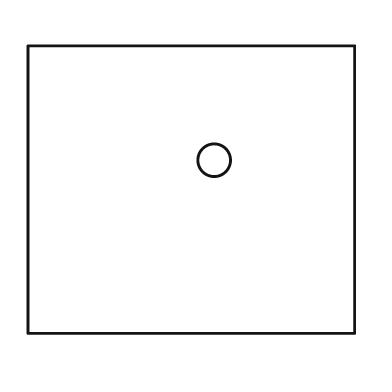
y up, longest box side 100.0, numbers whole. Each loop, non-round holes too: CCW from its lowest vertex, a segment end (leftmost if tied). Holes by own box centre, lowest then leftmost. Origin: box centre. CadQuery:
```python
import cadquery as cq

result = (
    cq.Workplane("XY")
    .moveTo(-50.0, -44.0)
    .lineTo(50.0, -44.0)
    .lineTo(50.0, 44.0)
    .lineTo(-50.0, 44.0)
    .close()
    .moveTo(7.0, 9.0)
    .circle(5.0)
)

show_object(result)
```